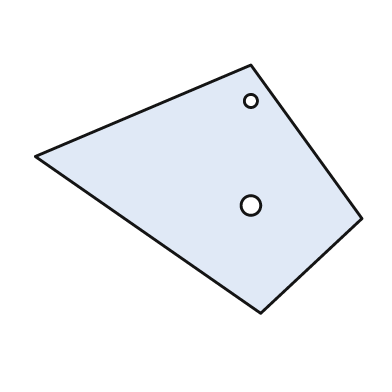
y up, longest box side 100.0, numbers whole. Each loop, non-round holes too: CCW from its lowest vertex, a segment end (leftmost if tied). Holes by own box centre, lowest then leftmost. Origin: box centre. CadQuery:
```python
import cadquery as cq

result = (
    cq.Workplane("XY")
    .moveTo(19.0, -38.0)
    .lineTo(50.0, -9.0)
    .lineTo(16.0, 38.0)
    .lineTo(-50.0, 10.0)
    .close()
    .moveTo(16.0, -5.0)
    .circle(3.0)
    .moveTo(16.0, 27.0)
    .circle(2.0)
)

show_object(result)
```